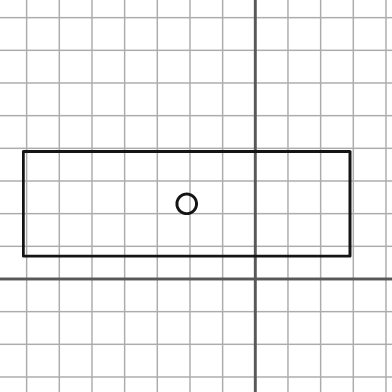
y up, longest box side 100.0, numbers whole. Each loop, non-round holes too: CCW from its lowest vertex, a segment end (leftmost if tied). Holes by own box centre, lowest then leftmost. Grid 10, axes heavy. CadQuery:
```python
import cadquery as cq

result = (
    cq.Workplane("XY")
    .moveTo(-71.0, 7.0)
    .lineTo(29.0, 7.0)
    .lineTo(29.0, 39.0)
    .lineTo(-71.0, 39.0)
    .close()
    .moveTo(-21.0, 23.0)
    .circle(3.0)
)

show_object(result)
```